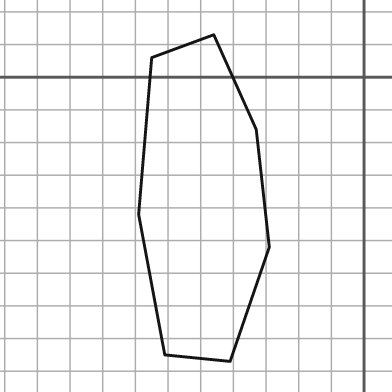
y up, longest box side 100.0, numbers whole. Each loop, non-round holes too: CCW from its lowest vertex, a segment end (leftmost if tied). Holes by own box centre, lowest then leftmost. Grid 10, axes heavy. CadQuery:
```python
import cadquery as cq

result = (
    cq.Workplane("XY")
    .moveTo(-41.0, -87.0)
    .lineTo(-29.0, -52.0)
    .lineTo(-33.0, -16.0)
    .lineTo(-46.0, 13.0)
    .lineTo(-65.0, 6.0)
    .lineTo(-69.0, -42.0)
    .lineTo(-61.0, -85.0)
    .close()
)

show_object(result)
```